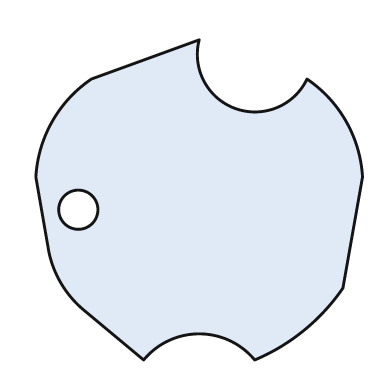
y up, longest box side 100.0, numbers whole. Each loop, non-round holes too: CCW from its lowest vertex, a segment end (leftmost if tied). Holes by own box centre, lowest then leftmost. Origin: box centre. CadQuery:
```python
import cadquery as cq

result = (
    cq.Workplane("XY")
    .moveTo(-17.0, -49.0)
    .threePointArc((0.0, -41.0), (17.0, -49.0))
    .threePointArc((32.0, -40.0), (44.0, -27.0))
    .lineTo(50.0, 7.0)
    .threePointArc((45.0, 24.0), (33.0, 37.0))
    .threePointArc((11.0, 28.0), (0.0, 49.0))
    .lineTo(-33.0, 37.0)
    .threePointArc((-45.0, 24.0), (-50.0, 7.0))
    .lineTo(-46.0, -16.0)
    .threePointArc((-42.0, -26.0), (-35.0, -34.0))
    .close()
    .moveTo(-37.0, -3.0)
    .circle(6.0)
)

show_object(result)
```